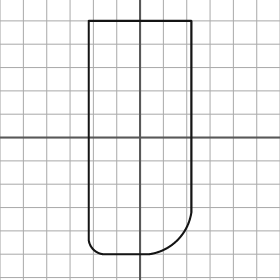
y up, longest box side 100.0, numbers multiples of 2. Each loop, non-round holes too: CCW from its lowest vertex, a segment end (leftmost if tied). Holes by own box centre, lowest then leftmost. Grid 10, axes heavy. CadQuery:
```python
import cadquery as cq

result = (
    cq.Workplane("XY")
    .moveTo(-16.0, -50.0)
    .lineTo(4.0, -50.0)
    .threePointArc((16.0, -44.0), (22.0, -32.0))
    .lineTo(22.0, 50.0)
    .lineTo(-22.0, 50.0)
    .lineTo(-22.0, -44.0)
    .threePointArc((-20.0, -48.0), (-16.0, -50.0))
    .close()
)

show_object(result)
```